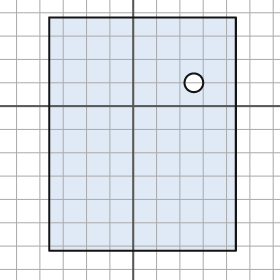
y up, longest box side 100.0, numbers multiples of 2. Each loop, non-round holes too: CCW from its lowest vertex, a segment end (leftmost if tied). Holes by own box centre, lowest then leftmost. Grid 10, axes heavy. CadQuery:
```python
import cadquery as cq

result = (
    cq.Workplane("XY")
    .moveTo(-36.0, -62.0)
    .lineTo(44.0, -62.0)
    .lineTo(44.0, 38.0)
    .lineTo(-36.0, 38.0)
    .close()
    .moveTo(26.0, 10.0)
    .circle(4.0)
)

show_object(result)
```